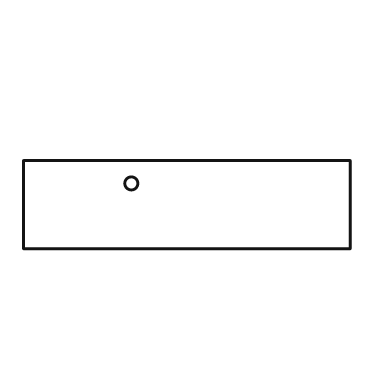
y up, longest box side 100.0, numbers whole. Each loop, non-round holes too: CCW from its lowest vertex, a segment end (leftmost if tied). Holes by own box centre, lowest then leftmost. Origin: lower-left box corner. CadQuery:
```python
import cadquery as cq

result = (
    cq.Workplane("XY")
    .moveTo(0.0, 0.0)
    .lineTo(100.0, 0.0)
    .lineTo(100.0, 27.0)
    .lineTo(0.0, 27.0)
    .close()
    .moveTo(33.0, 20.0)
    .circle(2.0)
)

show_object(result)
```